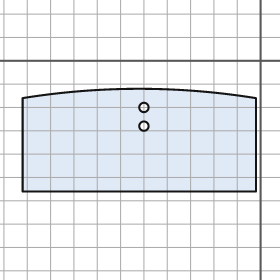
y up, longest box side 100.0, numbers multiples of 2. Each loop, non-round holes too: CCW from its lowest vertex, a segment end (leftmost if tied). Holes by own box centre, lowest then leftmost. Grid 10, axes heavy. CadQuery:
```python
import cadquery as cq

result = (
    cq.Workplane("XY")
    .moveTo(-102.0, -56.0)
    .lineTo(-2.0, -56.0)
    .lineTo(-2.0, -16.0)
    .threePointArc((-52.0, -12.0), (-102.0, -16.0))
    .close()
    .moveTo(-50.0, -28.0)
    .circle(2.0)
    .moveTo(-50.0, -20.0)
    .circle(2.0)
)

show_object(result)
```